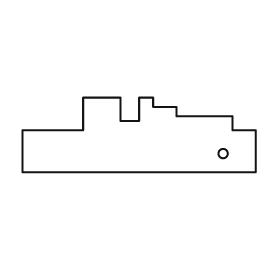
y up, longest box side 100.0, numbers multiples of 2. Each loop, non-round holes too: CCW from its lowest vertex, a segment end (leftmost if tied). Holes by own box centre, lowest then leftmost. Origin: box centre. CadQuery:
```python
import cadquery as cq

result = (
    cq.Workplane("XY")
    .moveTo(-50.0, -16.0)
    .lineTo(50.0, -16.0)
    .lineTo(50.0, 2.0)
    .lineTo(40.0, 2.0)
    .lineTo(40.0, 8.0)
    .lineTo(16.0, 8.0)
    .lineTo(16.0, 12.0)
    .lineTo(6.0, 12.0)
    .lineTo(6.0, 16.0)
    .lineTo(0.0, 16.0)
    .lineTo(0.0, 6.0)
    .lineTo(-8.0, 6.0)
    .lineTo(-8.0, 16.0)
    .lineTo(-24.0, 16.0)
    .lineTo(-24.0, 2.0)
    .lineTo(-50.0, 2.0)
    .close()
    .moveTo(36.0, -8.0)
    .circle(2.0)
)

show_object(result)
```